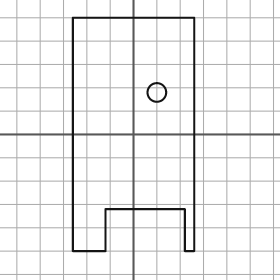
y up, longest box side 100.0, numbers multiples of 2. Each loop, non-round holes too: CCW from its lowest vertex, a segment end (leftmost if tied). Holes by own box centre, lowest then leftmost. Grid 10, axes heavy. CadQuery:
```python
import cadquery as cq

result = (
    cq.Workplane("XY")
    .moveTo(-26.0, -50.0)
    .lineTo(-12.0, -50.0)
    .lineTo(-12.0, -32.0)
    .lineTo(22.0, -32.0)
    .lineTo(22.0, -50.0)
    .lineTo(26.0, -50.0)
    .lineTo(26.0, 50.0)
    .lineTo(-26.0, 50.0)
    .close()
    .moveTo(10.0, 18.0)
    .circle(4.0)
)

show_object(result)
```